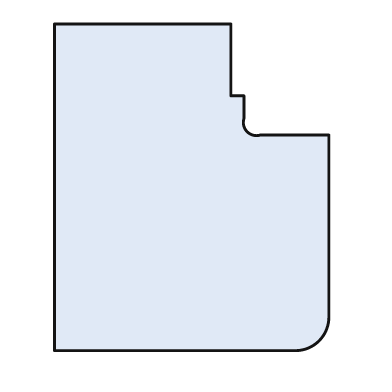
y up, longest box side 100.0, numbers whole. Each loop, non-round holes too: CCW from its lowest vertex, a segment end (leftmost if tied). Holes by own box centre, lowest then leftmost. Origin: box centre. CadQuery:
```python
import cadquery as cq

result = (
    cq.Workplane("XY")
    .moveTo(-42.0, -50.0)
    .lineTo(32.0, -50.0)
    .threePointArc((39.0, -47.0), (42.0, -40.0))
    .lineTo(42.0, 16.0)
    .lineTo(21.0, 16.0)
    .threePointArc((17.0, 17.0), (16.0, 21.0))
    .lineTo(16.0, 28.0)
    .lineTo(12.0, 28.0)
    .lineTo(12.0, 50.0)
    .lineTo(-42.0, 50.0)
    .close()
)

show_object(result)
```